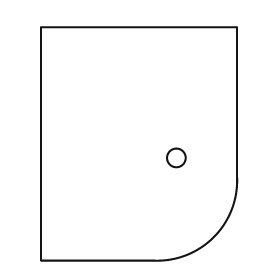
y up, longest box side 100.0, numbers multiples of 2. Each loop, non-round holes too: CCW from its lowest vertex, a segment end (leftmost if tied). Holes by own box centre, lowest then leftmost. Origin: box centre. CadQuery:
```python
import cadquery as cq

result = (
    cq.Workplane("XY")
    .moveTo(-42.0, -50.0)
    .lineTo(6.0, -50.0)
    .threePointArc((32.0, -40.0), (42.0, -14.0))
    .lineTo(42.0, 50.0)
    .lineTo(-42.0, 50.0)
    .close()
    .moveTo(16.0, -6.0)
    .circle(4.0)
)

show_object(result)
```